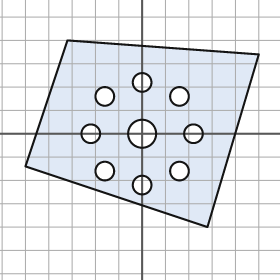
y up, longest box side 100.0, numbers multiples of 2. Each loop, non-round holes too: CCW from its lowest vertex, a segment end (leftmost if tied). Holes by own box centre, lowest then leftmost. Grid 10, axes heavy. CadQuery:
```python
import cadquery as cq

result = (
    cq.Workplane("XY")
    .moveTo(28.0, -40.0)
    .lineTo(50.0, 34.0)
    .lineTo(-32.0, 40.0)
    .lineTo(-50.0, -14.0)
    .close()
    .moveTo(0.0, -22.0)
    .circle(4.0)
    .moveTo(-16.0, -16.0)
    .circle(4.0)
    .moveTo(16.0, -16.0)
    .circle(4.0)
    .moveTo(-22.0, 0.0)
    .circle(4.0)
    .moveTo(0.0, 0.0)
    .circle(6.0)
    .moveTo(22.0, 0.0)
    .circle(4.0)
    .moveTo(-16.0, 16.0)
    .circle(4.0)
    .moveTo(16.0, 16.0)
    .circle(4.0)
    .moveTo(0.0, 22.0)
    .circle(4.0)
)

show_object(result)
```